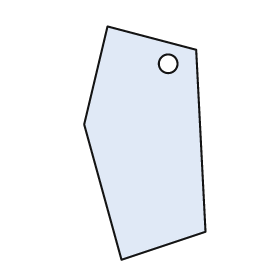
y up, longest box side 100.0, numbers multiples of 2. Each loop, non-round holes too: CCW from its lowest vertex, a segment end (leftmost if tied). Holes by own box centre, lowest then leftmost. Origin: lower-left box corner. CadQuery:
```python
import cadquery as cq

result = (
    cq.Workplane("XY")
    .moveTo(16.0, 0.0)
    .lineTo(52.0, 12.0)
    .lineTo(48.0, 90.0)
    .lineTo(10.0, 100.0)
    .lineTo(0.0, 58.0)
    .close()
    .moveTo(36.0, 84.0)
    .circle(4.0)
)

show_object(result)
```